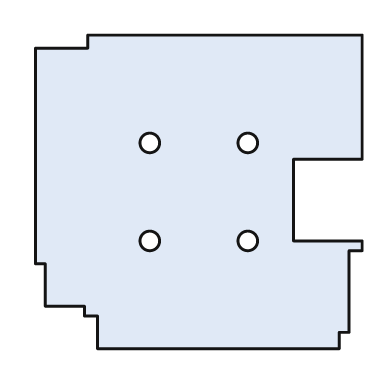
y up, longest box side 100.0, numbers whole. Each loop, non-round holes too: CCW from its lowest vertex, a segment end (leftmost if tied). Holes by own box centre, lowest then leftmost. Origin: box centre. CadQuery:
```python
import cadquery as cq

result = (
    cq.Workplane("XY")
    .moveTo(-31.0, -48.0)
    .lineTo(43.0, -48.0)
    .lineTo(43.0, -43.0)
    .lineTo(46.0, -43.0)
    .lineTo(46.0, -18.0)
    .lineTo(50.0, -18.0)
    .lineTo(50.0, -15.0)
    .lineTo(29.0, -15.0)
    .lineTo(29.0, 10.0)
    .lineTo(50.0, 10.0)
    .lineTo(50.0, 48.0)
    .lineTo(-34.0, 48.0)
    .lineTo(-34.0, 44.0)
    .lineTo(-50.0, 44.0)
    .lineTo(-50.0, -22.0)
    .lineTo(-47.0, -22.0)
    .lineTo(-47.0, -35.0)
    .lineTo(-35.0, -35.0)
    .lineTo(-35.0, -38.0)
    .lineTo(-31.0, -38.0)
    .close()
    .moveTo(-15.0, -15.0)
    .circle(3.0)
    .moveTo(15.0, -15.0)
    .circle(3.0)
    .moveTo(-15.0, 15.0)
    .circle(3.0)
    .moveTo(15.0, 15.0)
    .circle(3.0)
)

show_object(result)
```